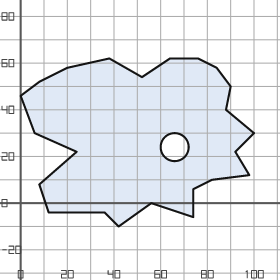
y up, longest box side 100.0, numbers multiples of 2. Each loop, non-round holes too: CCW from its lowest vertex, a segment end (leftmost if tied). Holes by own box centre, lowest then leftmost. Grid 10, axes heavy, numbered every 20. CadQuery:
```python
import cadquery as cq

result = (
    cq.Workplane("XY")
    .moveTo(42.0, -10.0)
    .lineTo(56.0, 0.0)
    .lineTo(74.0, -6.0)
    .lineTo(74.0, 6.0)
    .lineTo(82.0, 10.0)
    .lineTo(98.0, 12.0)
    .lineTo(92.0, 22.0)
    .lineTo(100.0, 30.0)
    .lineTo(88.0, 40.0)
    .lineTo(90.0, 50.0)
    .lineTo(84.0, 58.0)
    .lineTo(76.0, 62.0)
    .lineTo(64.0, 62.0)
    .lineTo(52.0, 54.0)
    .lineTo(38.0, 62.0)
    .lineTo(20.0, 58.0)
    .lineTo(8.0, 52.0)
    .lineTo(0.0, 46.0)
    .lineTo(6.0, 30.0)
    .lineTo(24.0, 22.0)
    .lineTo(8.0, 8.0)
    .lineTo(12.0, -4.0)
    .lineTo(36.0, -4.0)
    .close()
    .moveTo(66.0, 24.0)
    .circle(6.0)
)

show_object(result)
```